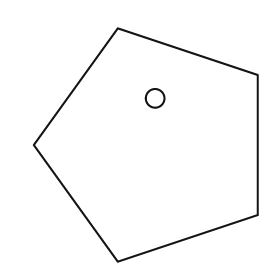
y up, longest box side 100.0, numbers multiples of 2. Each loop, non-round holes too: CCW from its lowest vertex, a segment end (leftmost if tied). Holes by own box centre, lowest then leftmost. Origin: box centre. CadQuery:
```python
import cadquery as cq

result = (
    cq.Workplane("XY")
    .moveTo(-12.0, -50.0)
    .lineTo(48.0, -30.0)
    .lineTo(48.0, 30.0)
    .lineTo(-12.0, 50.0)
    .lineTo(-48.0, 0.0)
    .close()
    .moveTo(4.0, 20.0)
    .circle(4.0)
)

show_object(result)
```